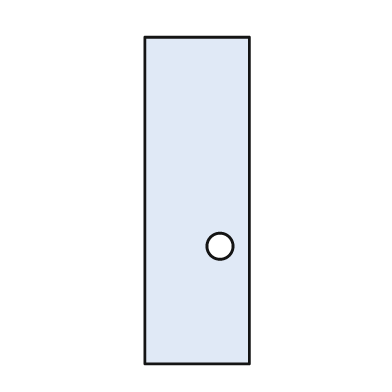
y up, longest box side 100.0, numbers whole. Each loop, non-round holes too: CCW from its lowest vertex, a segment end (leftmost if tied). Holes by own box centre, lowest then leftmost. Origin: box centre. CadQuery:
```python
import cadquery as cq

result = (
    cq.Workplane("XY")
    .moveTo(-16.0, -50.0)
    .lineTo(16.0, -50.0)
    .lineTo(16.0, 50.0)
    .lineTo(-16.0, 50.0)
    .close()
    .moveTo(7.0, -14.0)
    .circle(4.0)
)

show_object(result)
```